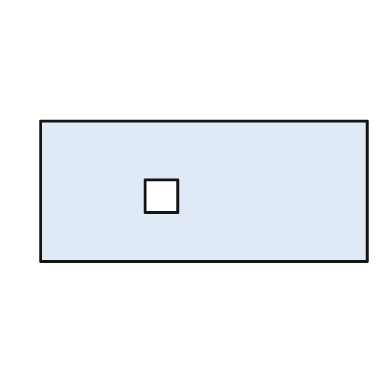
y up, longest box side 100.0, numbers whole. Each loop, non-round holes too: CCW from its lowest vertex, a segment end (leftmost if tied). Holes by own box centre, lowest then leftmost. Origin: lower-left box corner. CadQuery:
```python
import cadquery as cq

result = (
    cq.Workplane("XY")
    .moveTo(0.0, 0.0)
    .lineTo(100.0, 0.0)
    .lineTo(100.0, 43.0)
    .lineTo(0.0, 43.0)
    .close()
    .moveTo(32.0, 15.0)
    .lineTo(42.0, 15.0)
    .lineTo(42.0, 25.0)
    .lineTo(32.0, 25.0)
    .close()
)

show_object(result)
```